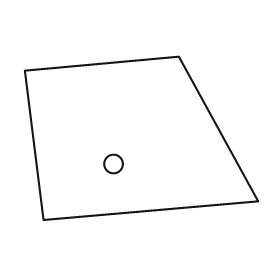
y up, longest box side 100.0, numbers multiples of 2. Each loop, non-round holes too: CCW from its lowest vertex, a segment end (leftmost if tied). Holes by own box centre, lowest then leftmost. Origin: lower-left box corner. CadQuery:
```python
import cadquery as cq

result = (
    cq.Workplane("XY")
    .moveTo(8.0, 0.0)
    .lineTo(100.0, 8.0)
    .lineTo(66.0, 70.0)
    .lineTo(0.0, 64.0)
    .close()
    .moveTo(38.0, 24.0)
    .circle(4.0)
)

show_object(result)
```